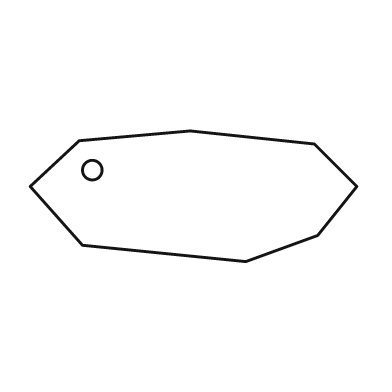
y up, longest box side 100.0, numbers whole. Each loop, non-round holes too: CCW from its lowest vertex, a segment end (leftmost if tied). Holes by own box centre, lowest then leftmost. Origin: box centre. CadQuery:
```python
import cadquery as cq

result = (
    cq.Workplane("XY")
    .moveTo(16.0, -20.0)
    .lineTo(38.0, -12.0)
    .lineTo(50.0, 3.0)
    .lineTo(37.0, 16.0)
    .lineTo(-1.0, 20.0)
    .lineTo(-35.0, 17.0)
    .lineTo(-50.0, 3.0)
    .lineTo(-34.0, -15.0)
    .close()
    .moveTo(-31.0, 8.0)
    .circle(3.0)
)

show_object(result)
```